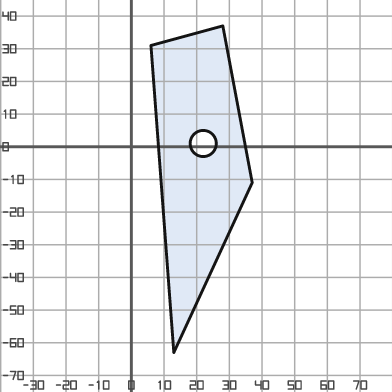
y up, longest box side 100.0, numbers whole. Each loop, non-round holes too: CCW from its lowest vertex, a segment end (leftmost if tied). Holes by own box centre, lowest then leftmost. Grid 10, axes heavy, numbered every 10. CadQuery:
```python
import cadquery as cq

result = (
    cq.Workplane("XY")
    .moveTo(13.0, -63.0)
    .lineTo(37.0, -11.0)
    .lineTo(28.0, 37.0)
    .lineTo(6.0, 31.0)
    .close()
    .moveTo(22.0, 1.0)
    .circle(4.0)
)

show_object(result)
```